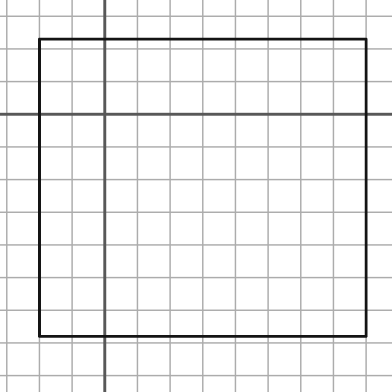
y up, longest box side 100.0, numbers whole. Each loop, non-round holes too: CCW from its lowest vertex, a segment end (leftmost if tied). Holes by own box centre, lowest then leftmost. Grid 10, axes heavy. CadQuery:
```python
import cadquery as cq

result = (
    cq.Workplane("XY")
    .moveTo(-20.0, -68.0)
    .lineTo(80.0, -68.0)
    .lineTo(80.0, 23.0)
    .lineTo(-20.0, 23.0)
    .close()
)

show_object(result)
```